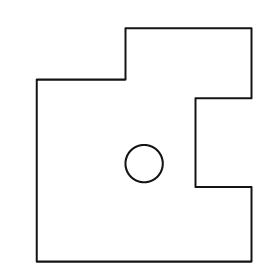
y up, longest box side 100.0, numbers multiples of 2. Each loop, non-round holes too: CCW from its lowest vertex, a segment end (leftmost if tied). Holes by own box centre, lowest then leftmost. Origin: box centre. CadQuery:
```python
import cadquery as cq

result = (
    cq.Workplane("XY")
    .moveTo(-46.0, -50.0)
    .lineTo(46.0, -50.0)
    .lineTo(46.0, -18.0)
    .lineTo(22.0, -18.0)
    .lineTo(22.0, 20.0)
    .lineTo(46.0, 20.0)
    .lineTo(46.0, 50.0)
    .lineTo(-8.0, 50.0)
    .lineTo(-8.0, 28.0)
    .lineTo(-46.0, 28.0)
    .close()
    .moveTo(0.0, -8.0)
    .circle(8.0)
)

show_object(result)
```